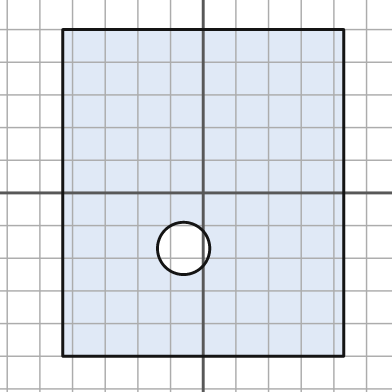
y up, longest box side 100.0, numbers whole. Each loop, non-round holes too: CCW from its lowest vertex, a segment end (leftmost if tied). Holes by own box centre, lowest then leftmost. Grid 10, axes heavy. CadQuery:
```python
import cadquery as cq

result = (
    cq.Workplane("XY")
    .moveTo(-43.0, -50.0)
    .lineTo(43.0, -50.0)
    .lineTo(43.0, 50.0)
    .lineTo(-43.0, 50.0)
    .close()
    .moveTo(-6.0, -17.0)
    .circle(8.0)
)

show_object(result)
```